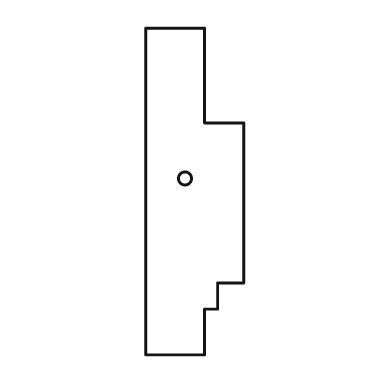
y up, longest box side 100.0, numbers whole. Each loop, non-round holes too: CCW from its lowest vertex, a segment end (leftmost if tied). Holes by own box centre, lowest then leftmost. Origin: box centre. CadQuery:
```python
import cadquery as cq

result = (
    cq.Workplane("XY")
    .moveTo(-15.0, -50.0)
    .lineTo(3.0, -50.0)
    .lineTo(3.0, -36.0)
    .lineTo(7.0, -36.0)
    .lineTo(7.0, -28.0)
    .lineTo(15.0, -28.0)
    .lineTo(15.0, 21.0)
    .lineTo(3.0, 21.0)
    .lineTo(3.0, 50.0)
    .lineTo(-15.0, 50.0)
    .close()
    .moveTo(-3.0, 4.0)
    .circle(2.0)
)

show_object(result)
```